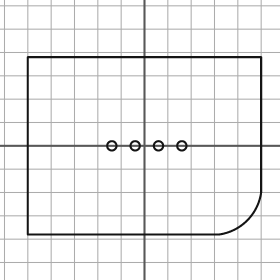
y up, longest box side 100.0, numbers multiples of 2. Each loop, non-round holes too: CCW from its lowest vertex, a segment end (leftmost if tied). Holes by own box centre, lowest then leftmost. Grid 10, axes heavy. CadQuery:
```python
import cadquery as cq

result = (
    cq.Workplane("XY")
    .moveTo(-50.0, -38.0)
    .lineTo(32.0, -38.0)
    .threePointArc((44.0, -32.0), (50.0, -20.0))
    .lineTo(50.0, 38.0)
    .lineTo(-50.0, 38.0)
    .close()
    .moveTo(-14.0, 0.0)
    .circle(2.0)
    .moveTo(-4.0, 0.0)
    .circle(2.0)
    .moveTo(6.0, 0.0)
    .circle(2.0)
    .moveTo(16.0, 0.0)
    .circle(2.0)
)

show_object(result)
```